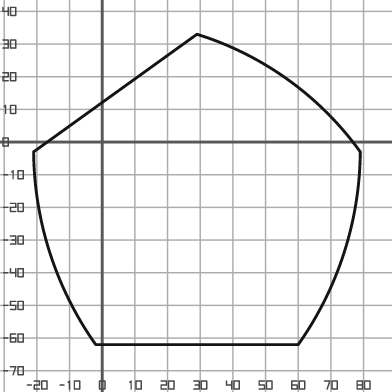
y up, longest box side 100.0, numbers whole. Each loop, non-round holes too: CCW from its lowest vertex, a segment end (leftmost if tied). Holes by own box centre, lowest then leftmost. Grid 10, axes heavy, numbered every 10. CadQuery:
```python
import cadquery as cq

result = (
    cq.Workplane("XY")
    .moveTo(-2.0, -62.0)
    .lineTo(60.0, -62.0)
    .threePointArc((74.0, -34.0), (79.0, -3.0))
    .threePointArc((57.0, 19.0), (29.0, 33.0))
    .lineTo(-21.0, -3.0)
    .threePointArc((-16.0, -34.0), (-2.0, -62.0))
    .close()
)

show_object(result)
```